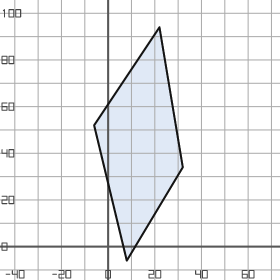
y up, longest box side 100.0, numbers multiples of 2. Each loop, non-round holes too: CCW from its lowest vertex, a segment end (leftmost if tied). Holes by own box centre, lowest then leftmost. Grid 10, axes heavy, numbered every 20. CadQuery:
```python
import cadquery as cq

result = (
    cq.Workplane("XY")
    .moveTo(8.0, -6.0)
    .lineTo(32.0, 34.0)
    .lineTo(22.0, 94.0)
    .lineTo(-6.0, 52.0)
    .close()
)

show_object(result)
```